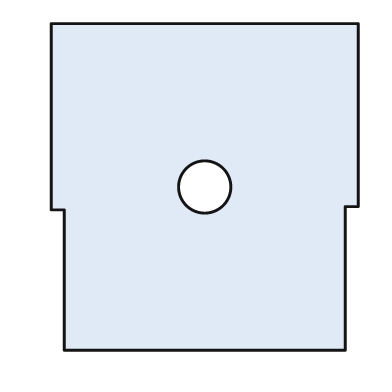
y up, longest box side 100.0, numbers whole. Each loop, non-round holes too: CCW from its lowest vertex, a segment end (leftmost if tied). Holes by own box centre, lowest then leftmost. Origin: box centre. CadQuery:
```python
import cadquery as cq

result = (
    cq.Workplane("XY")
    .moveTo(-43.0, -50.0)
    .lineTo(43.0, -50.0)
    .lineTo(43.0, -6.0)
    .lineTo(47.0, -6.0)
    .lineTo(47.0, 50.0)
    .lineTo(-47.0, 50.0)
    .lineTo(-47.0, -7.0)
    .lineTo(-43.0, -7.0)
    .close()
    .moveTo(0.0, 0.0)
    .circle(8.0)
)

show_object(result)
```